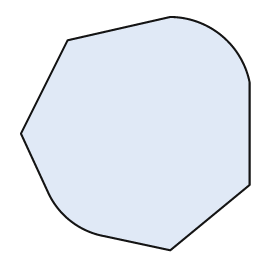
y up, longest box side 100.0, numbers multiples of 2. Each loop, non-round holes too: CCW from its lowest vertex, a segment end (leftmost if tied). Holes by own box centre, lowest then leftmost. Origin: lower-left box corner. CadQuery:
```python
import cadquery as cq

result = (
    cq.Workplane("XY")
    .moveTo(64.0, 0.0)
    .lineTo(98.0, 28.0)
    .lineTo(98.0, 72.0)
    .threePointArc((86.0, 92.0), (64.0, 100.0))
    .lineTo(20.0, 90.0)
    .lineTo(0.0, 50.0)
    .lineTo(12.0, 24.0)
    .threePointArc((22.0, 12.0), (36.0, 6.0))
    .close()
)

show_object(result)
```